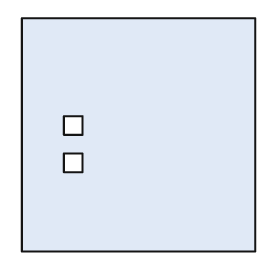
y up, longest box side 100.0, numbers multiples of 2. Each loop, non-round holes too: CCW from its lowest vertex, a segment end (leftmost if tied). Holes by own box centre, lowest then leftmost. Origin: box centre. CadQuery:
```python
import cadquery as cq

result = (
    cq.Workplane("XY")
    .moveTo(-50.0, -50.0)
    .lineTo(50.0, -50.0)
    .lineTo(50.0, 50.0)
    .lineTo(-50.0, 50.0)
    .close()
    .moveTo(-32.0, -16.0)
    .lineTo(-24.0, -16.0)
    .lineTo(-24.0, -8.0)
    .lineTo(-32.0, -8.0)
    .close()
    .moveTo(-32.0, 0.0)
    .lineTo(-24.0, 0.0)
    .lineTo(-24.0, 8.0)
    .lineTo(-32.0, 8.0)
    .close()
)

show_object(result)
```